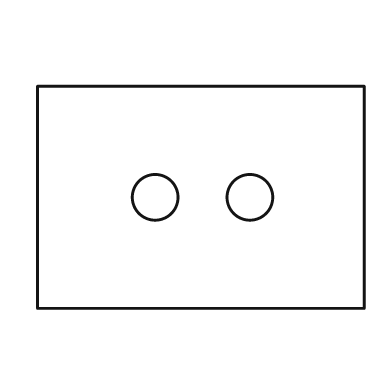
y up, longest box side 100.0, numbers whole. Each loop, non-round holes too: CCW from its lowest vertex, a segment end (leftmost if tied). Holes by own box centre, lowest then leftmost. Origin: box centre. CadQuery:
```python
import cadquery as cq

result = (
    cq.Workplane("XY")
    .moveTo(-50.0, -34.0)
    .lineTo(50.0, -34.0)
    .lineTo(50.0, 34.0)
    .lineTo(-50.0, 34.0)
    .close()
    .moveTo(-14.0, 0.0)
    .circle(7.0)
    .moveTo(15.0, 0.0)
    .circle(7.0)
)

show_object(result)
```